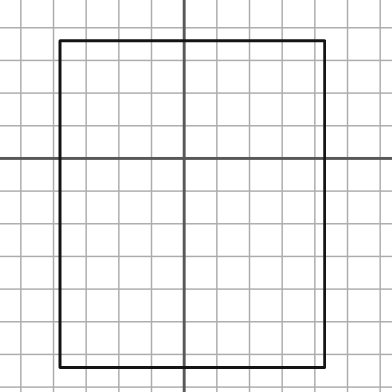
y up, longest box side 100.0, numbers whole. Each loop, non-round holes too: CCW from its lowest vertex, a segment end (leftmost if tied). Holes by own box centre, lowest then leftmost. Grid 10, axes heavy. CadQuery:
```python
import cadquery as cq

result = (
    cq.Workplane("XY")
    .moveTo(-38.0, -64.0)
    .lineTo(43.0, -64.0)
    .lineTo(43.0, 36.0)
    .lineTo(-38.0, 36.0)
    .close()
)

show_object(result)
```